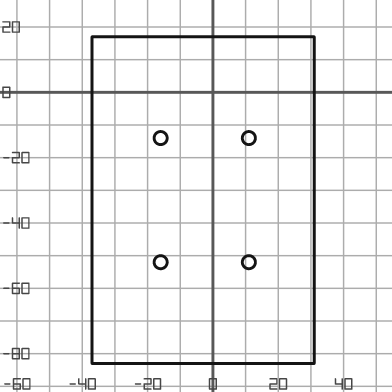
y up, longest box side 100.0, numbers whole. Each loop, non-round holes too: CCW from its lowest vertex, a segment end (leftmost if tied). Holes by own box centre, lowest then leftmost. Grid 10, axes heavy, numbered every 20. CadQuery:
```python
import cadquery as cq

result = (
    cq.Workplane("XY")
    .moveTo(-37.0, -83.0)
    .lineTo(31.0, -83.0)
    .lineTo(31.0, 17.0)
    .lineTo(-37.0, 17.0)
    .close()
    .moveTo(-16.0, -52.0)
    .circle(2.0)
    .moveTo(11.0, -52.0)
    .circle(2.0)
    .moveTo(-16.0, -14.0)
    .circle(2.0)
    .moveTo(11.0, -14.0)
    .circle(2.0)
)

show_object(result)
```